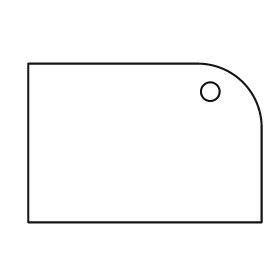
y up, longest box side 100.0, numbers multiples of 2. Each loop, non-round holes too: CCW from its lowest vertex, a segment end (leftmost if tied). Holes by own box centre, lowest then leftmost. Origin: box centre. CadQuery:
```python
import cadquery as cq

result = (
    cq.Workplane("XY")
    .moveTo(-50.0, -34.0)
    .lineTo(50.0, -34.0)
    .lineTo(50.0, 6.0)
    .threePointArc((42.0, 26.0), (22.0, 34.0))
    .lineTo(-50.0, 34.0)
    .close()
    .moveTo(28.0, 22.0)
    .circle(4.0)
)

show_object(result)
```